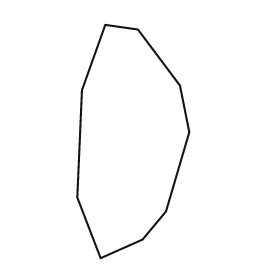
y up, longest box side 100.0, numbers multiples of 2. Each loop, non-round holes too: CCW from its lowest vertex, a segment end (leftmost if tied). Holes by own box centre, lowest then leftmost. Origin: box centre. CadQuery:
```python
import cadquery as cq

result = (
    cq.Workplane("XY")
    .moveTo(-14.0, -50.0)
    .lineTo(4.0, -42.0)
    .lineTo(14.0, -30.0)
    .lineTo(24.0, 4.0)
    .lineTo(20.0, 24.0)
    .lineTo(2.0, 48.0)
    .lineTo(-12.0, 50.0)
    .lineTo(-22.0, 22.0)
    .lineTo(-24.0, -24.0)
    .close()
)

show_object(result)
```